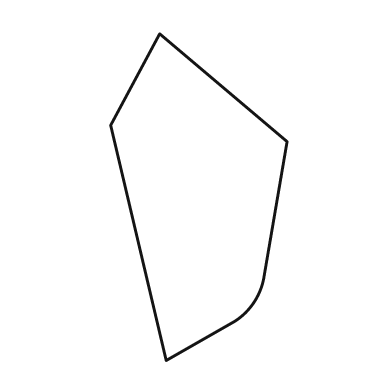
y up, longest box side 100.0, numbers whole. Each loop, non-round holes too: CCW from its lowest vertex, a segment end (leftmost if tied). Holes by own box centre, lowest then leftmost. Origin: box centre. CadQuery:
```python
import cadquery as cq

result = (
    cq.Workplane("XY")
    .moveTo(-10.0, -50.0)
    .lineTo(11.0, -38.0)
    .threePointArc((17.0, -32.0), (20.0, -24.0))
    .lineTo(27.0, 17.0)
    .lineTo(-12.0, 50.0)
    .lineTo(-27.0, 22.0)
    .close()
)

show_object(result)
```